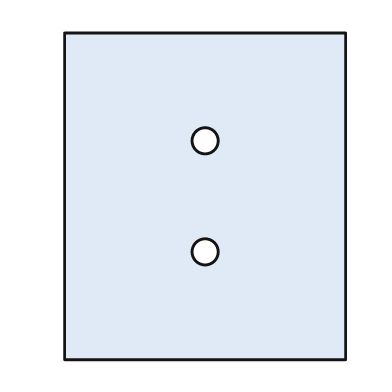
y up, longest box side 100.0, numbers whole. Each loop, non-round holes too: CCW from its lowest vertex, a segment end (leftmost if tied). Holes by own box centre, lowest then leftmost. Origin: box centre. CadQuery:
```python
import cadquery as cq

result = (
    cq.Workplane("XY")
    .moveTo(-43.0, -50.0)
    .lineTo(43.0, -50.0)
    .lineTo(43.0, 50.0)
    .lineTo(-43.0, 50.0)
    .close()
    .moveTo(0.0, -17.0)
    .circle(4.0)
    .moveTo(0.0, 17.0)
    .circle(4.0)
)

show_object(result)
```